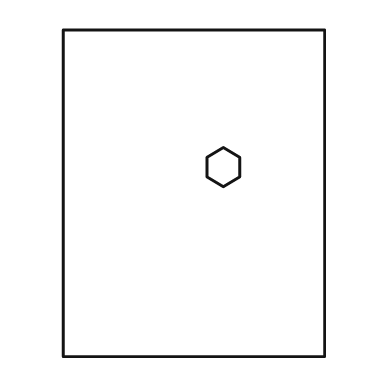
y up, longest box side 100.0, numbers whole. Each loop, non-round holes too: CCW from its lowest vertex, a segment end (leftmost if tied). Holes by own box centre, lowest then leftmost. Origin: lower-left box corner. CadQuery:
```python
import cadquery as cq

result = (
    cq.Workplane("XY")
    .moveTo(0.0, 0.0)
    .lineTo(80.0, 0.0)
    .lineTo(80.0, 100.0)
    .lineTo(0.0, 100.0)
    .close()
    .moveTo(49.0, 52.0)
    .lineTo(54.0, 55.0)
    .lineTo(54.0, 61.0)
    .lineTo(49.0, 64.0)
    .lineTo(44.0, 61.0)
    .lineTo(44.0, 55.0)
    .close()
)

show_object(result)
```